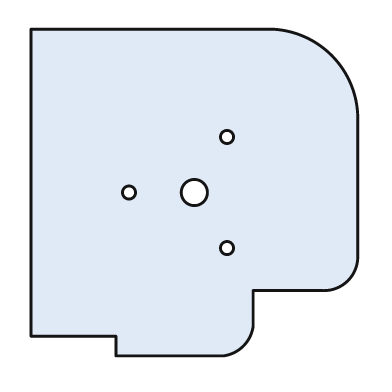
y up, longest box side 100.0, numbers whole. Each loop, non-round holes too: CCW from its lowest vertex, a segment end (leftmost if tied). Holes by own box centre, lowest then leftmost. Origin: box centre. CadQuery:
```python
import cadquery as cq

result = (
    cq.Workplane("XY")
    .moveTo(-24.0, -50.0)
    .lineTo(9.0, -50.0)
    .threePointArc((15.0, -47.0), (18.0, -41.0))
    .lineTo(18.0, -30.0)
    .lineTo(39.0, -30.0)
    .threePointArc((47.0, -27.0), (50.0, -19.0))
    .lineTo(50.0, 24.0)
    .threePointArc((42.0, 42.0), (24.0, 50.0))
    .lineTo(-50.0, 50.0)
    .lineTo(-50.0, -44.0)
    .lineTo(-24.0, -44.0)
    .close()
    .moveTo(10.0, -17.0)
    .circle(2.0)
    .moveTo(-20.0, 0.0)
    .circle(2.0)
    .moveTo(0.0, 0.0)
    .circle(4.0)
    .moveTo(10.0, 17.0)
    .circle(2.0)
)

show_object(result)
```